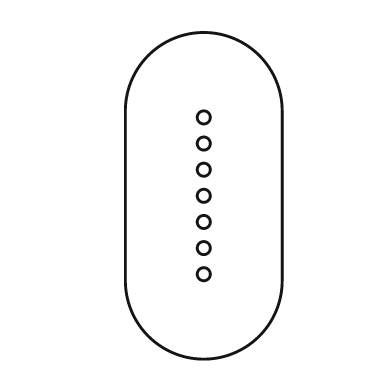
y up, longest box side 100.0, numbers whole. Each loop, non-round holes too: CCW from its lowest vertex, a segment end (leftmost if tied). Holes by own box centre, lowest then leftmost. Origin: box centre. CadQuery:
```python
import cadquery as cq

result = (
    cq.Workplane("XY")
    .moveTo(-24.0, -26.0)
    .threePointArc((0.0, -50.0), (24.0, -26.0))
    .lineTo(24.0, 26.0)
    .threePointArc((0.0, 50.0), (-24.0, 26.0))
    .close()
    .moveTo(0.0, -24.0)
    .circle(2.0)
    .moveTo(0.0, -16.0)
    .circle(2.0)
    .moveTo(0.0, -8.0)
    .circle(2.0)
    .moveTo(0.0, 0.0)
    .circle(2.0)
    .moveTo(0.0, 8.0)
    .circle(2.0)
    .moveTo(0.0, 16.0)
    .circle(2.0)
    .moveTo(0.0, 24.0)
    .circle(2.0)
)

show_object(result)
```